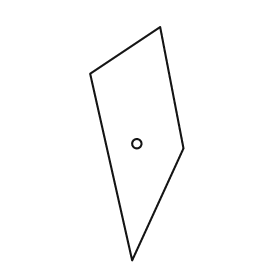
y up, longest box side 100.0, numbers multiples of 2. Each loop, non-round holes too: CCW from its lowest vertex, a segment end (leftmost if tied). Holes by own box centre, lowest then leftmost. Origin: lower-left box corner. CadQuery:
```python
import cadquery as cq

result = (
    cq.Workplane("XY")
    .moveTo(18.0, 0.0)
    .lineTo(40.0, 48.0)
    .lineTo(30.0, 100.0)
    .lineTo(0.0, 80.0)
    .close()
    .moveTo(20.0, 50.0)
    .circle(2.0)
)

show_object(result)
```